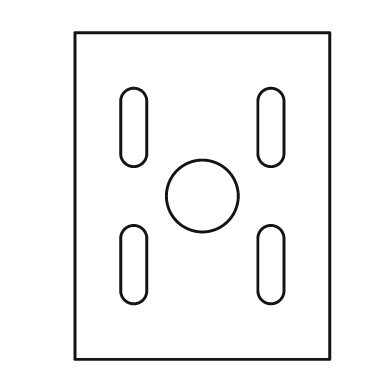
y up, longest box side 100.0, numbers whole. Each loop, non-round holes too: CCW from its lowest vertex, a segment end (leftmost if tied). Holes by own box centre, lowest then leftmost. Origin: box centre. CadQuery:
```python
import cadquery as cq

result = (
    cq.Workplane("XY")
    .moveTo(-39.0, -50.0)
    .lineTo(39.0, -50.0)
    .lineTo(39.0, 50.0)
    .lineTo(-39.0, 50.0)
    .close()
    .moveTo(-25.0, -29.0)
    .threePointArc((-21.0, -33.0), (-17.0, -29.0))
    .lineTo(-17.0, -13.0)
    .threePointArc((-21.0, -9.0), (-25.0, -13.0))
    .close()
    .moveTo(17.0, -29.0)
    .threePointArc((21.0, -33.0), (25.0, -29.0))
    .lineTo(25.0, -13.0)
    .threePointArc((21.0, -9.0), (17.0, -13.0))
    .close()
    .moveTo(0.0, 0.0)
    .circle(11.0)
    .moveTo(-25.0, 13.0)
    .threePointArc((-21.0, 9.0), (-17.0, 13.0))
    .lineTo(-17.0, 29.0)
    .threePointArc((-21.0, 33.0), (-25.0, 29.0))
    .close()
    .moveTo(17.0, 13.0)
    .threePointArc((21.0, 9.0), (25.0, 13.0))
    .lineTo(25.0, 29.0)
    .threePointArc((21.0, 33.0), (17.0, 29.0))
    .close()
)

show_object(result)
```